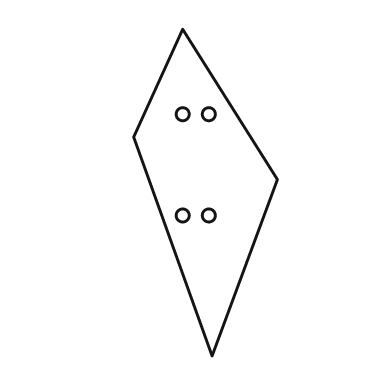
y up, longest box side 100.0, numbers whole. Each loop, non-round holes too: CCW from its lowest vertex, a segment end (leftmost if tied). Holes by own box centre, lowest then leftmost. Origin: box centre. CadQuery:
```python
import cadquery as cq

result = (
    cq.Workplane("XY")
    .moveTo(2.0, -50.0)
    .lineTo(22.0, 4.0)
    .lineTo(-7.0, 50.0)
    .lineTo(-22.0, 17.0)
    .close()
    .moveTo(-7.0, -7.0)
    .circle(2.0)
    .moveTo(1.0, -7.0)
    .circle(2.0)
    .moveTo(-7.0, 24.0)
    .circle(2.0)
    .moveTo(1.0, 24.0)
    .circle(2.0)
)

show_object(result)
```